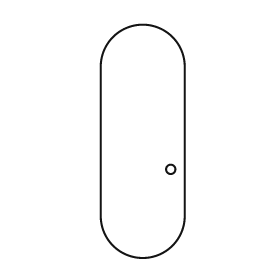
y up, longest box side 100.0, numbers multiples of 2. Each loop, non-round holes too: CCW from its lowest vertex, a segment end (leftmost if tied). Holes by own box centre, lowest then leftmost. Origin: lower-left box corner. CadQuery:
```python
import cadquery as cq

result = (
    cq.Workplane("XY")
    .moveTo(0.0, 18.0)
    .threePointArc((18.0, 0.0), (36.0, 18.0))
    .lineTo(36.0, 82.0)
    .threePointArc((18.0, 100.0), (0.0, 82.0))
    .close()
    .moveTo(30.0, 38.0)
    .circle(2.0)
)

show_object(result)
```